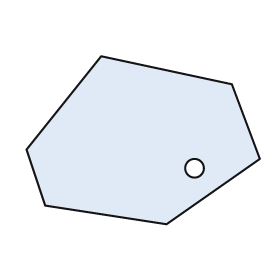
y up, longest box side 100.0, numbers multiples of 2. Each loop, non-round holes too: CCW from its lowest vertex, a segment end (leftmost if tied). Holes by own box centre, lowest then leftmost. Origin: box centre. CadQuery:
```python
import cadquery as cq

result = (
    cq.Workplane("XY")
    .moveTo(10.0, -36.0)
    .lineTo(50.0, -8.0)
    .lineTo(38.0, 24.0)
    .lineTo(-18.0, 36.0)
    .lineTo(-50.0, -4.0)
    .lineTo(-42.0, -28.0)
    .close()
    .moveTo(22.0, -12.0)
    .circle(4.0)
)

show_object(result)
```